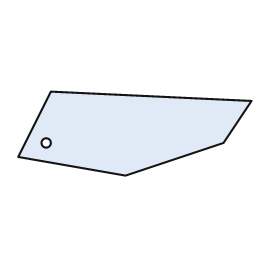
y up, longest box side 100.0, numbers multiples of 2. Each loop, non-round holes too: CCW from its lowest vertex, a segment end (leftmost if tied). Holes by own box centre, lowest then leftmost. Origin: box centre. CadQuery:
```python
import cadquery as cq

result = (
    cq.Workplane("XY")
    .moveTo(-4.0, -18.0)
    .lineTo(38.0, -4.0)
    .lineTo(50.0, 14.0)
    .lineTo(-36.0, 18.0)
    .lineTo(-50.0, -10.0)
    .close()
    .moveTo(-38.0, -4.0)
    .circle(2.0)
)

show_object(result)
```